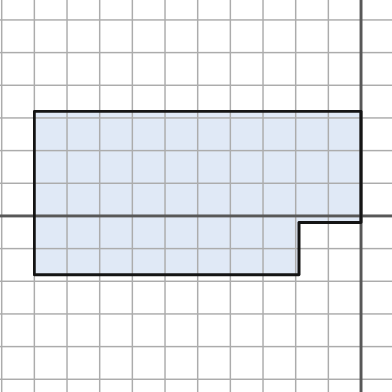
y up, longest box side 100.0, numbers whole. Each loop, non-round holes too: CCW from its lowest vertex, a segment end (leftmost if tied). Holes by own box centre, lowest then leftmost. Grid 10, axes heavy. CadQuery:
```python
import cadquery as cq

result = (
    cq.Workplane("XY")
    .moveTo(-100.0, -18.0)
    .lineTo(-19.0, -18.0)
    .lineTo(-19.0, -2.0)
    .lineTo(0.0, -2.0)
    .lineTo(0.0, 32.0)
    .lineTo(-100.0, 32.0)
    .close()
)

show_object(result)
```